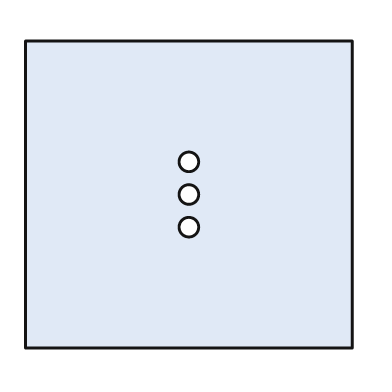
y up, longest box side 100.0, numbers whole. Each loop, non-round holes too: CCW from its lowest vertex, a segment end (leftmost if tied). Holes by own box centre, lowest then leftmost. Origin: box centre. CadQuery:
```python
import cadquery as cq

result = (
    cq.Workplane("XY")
    .moveTo(-50.0, -47.0)
    .lineTo(50.0, -47.0)
    .lineTo(50.0, 47.0)
    .lineTo(-50.0, 47.0)
    .close()
    .moveTo(0.0, -10.0)
    .circle(3.0)
    .moveTo(0.0, 0.0)
    .circle(3.0)
    .moveTo(0.0, 10.0)
    .circle(3.0)
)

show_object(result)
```